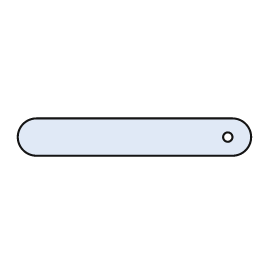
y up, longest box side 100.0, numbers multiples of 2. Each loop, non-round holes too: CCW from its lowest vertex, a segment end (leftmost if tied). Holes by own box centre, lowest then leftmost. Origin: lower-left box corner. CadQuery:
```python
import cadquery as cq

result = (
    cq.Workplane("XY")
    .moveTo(8.0, 0.0)
    .lineTo(92.0, 0.0)
    .threePointArc((100.0, 8.0), (92.0, 16.0))
    .lineTo(8.0, 16.0)
    .threePointArc((0.0, 8.0), (8.0, 0.0))
    .close()
    .moveTo(90.0, 8.0)
    .circle(2.0)
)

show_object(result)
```